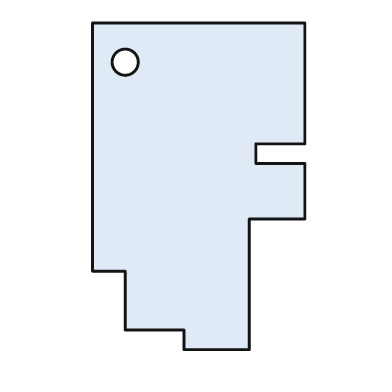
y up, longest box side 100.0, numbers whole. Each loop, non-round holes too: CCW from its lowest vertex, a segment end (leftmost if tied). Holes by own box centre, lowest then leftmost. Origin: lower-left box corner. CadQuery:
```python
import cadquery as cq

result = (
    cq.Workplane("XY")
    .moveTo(28.0, 0.0)
    .lineTo(48.0, 0.0)
    .lineTo(48.0, 40.0)
    .lineTo(65.0, 40.0)
    .lineTo(65.0, 57.0)
    .lineTo(50.0, 57.0)
    .lineTo(50.0, 63.0)
    .lineTo(65.0, 63.0)
    .lineTo(65.0, 100.0)
    .lineTo(0.0, 100.0)
    .lineTo(0.0, 24.0)
    .lineTo(10.0, 24.0)
    .lineTo(10.0, 6.0)
    .lineTo(28.0, 6.0)
    .close()
    .moveTo(10.0, 88.0)
    .circle(4.0)
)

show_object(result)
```